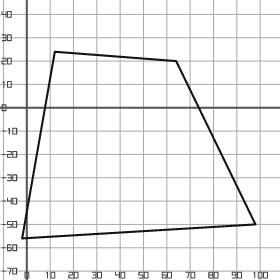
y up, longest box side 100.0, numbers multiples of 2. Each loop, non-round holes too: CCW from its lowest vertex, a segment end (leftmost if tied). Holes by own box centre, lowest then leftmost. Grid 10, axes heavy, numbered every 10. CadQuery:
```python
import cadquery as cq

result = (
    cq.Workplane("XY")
    .moveTo(-2.0, -56.0)
    .lineTo(98.0, -50.0)
    .lineTo(64.0, 20.0)
    .lineTo(12.0, 24.0)
    .close()
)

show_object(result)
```